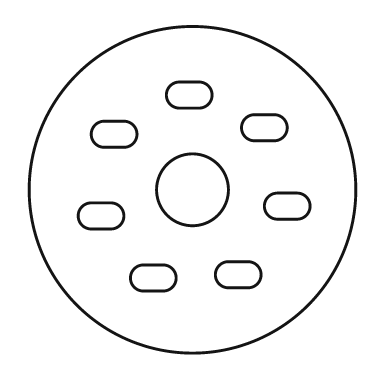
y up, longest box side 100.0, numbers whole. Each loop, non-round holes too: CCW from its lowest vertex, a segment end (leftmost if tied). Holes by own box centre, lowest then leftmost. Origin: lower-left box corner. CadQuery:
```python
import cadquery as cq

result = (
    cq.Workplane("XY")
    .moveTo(50.0, 50.0)
    .circle(50.0)
    .moveTo(35.0, 19.0)
    .lineTo(41.0, 19.0)
    .threePointArc((45.0, 23.0), (41.0, 27.0))
    .lineTo(35.0, 27.0)
    .threePointArc((31.0, 23.0), (35.0, 19.0))
    .close()
    .moveTo(61.0, 20.0)
    .lineTo(67.0, 20.0)
    .threePointArc((71.0, 24.0), (67.0, 28.0))
    .lineTo(61.0, 28.0)
    .threePointArc((57.0, 24.0), (61.0, 20.0))
    .close()
    .moveTo(19.0, 38.0)
    .lineTo(25.0, 38.0)
    .threePointArc((29.0, 42.0), (25.0, 46.0))
    .lineTo(19.0, 46.0)
    .threePointArc((15.0, 42.0), (19.0, 38.0))
    .close()
    .moveTo(76.0, 41.0)
    .lineTo(82.0, 41.0)
    .threePointArc((86.0, 45.0), (82.0, 49.0))
    .lineTo(76.0, 49.0)
    .threePointArc((72.0, 45.0), (76.0, 41.0))
    .close()
    .moveTo(50.0, 50.0)
    .circle(11.0)
    .moveTo(23.0, 63.0)
    .lineTo(29.0, 63.0)
    .threePointArc((33.0, 67.0), (29.0, 71.0))
    .lineTo(23.0, 71.0)
    .threePointArc((19.0, 67.0), (23.0, 63.0))
    .close()
    .moveTo(69.0, 65.0)
    .lineTo(75.0, 65.0)
    .threePointArc((79.0, 69.0), (75.0, 73.0))
    .lineTo(69.0, 73.0)
    .threePointArc((65.0, 69.0), (69.0, 65.0))
    .close()
    .moveTo(46.0, 75.0)
    .lineTo(52.0, 75.0)
    .threePointArc((56.0, 79.0), (52.0, 83.0))
    .lineTo(46.0, 83.0)
    .threePointArc((42.0, 79.0), (46.0, 75.0))
    .close()
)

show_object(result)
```